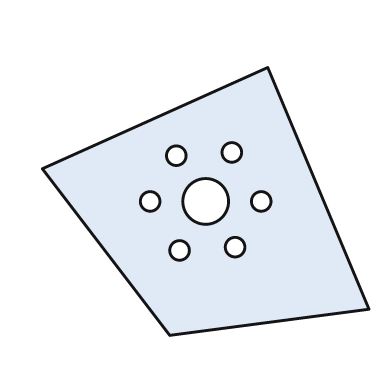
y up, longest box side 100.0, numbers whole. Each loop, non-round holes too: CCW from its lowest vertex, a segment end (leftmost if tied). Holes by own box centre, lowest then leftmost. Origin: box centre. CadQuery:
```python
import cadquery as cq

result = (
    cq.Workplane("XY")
    .moveTo(-11.0, -41.0)
    .lineTo(50.0, -33.0)
    .lineTo(19.0, 41.0)
    .lineTo(-50.0, 10.0)
    .close()
    .moveTo(-8.0, -15.0)
    .circle(3.0)
    .moveTo(9.0, -14.0)
    .circle(3.0)
    .moveTo(-17.0, 0.0)
    .circle(3.0)
    .moveTo(0.0, 0.0)
    .circle(7.0)
    .moveTo(17.0, 0.0)
    .circle(3.0)
    .moveTo(-9.0, 14.0)
    .circle(3.0)
    .moveTo(8.0, 15.0)
    .circle(3.0)
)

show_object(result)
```